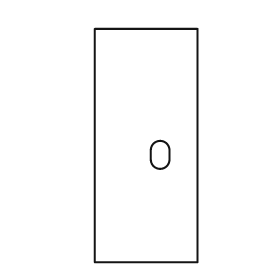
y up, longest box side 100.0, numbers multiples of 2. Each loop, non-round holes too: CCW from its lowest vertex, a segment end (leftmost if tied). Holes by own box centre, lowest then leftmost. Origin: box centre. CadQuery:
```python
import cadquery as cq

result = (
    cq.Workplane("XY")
    .moveTo(-22.0, -50.0)
    .lineTo(22.0, -50.0)
    .lineTo(22.0, 50.0)
    .lineTo(-22.0, 50.0)
    .close()
    .moveTo(2.0, -6.0)
    .threePointArc((6.0, -10.0), (10.0, -6.0))
    .lineTo(10.0, -2.0)
    .threePointArc((6.0, 2.0), (2.0, -2.0))
    .close()
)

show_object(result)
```